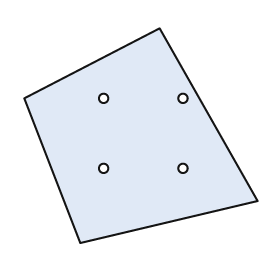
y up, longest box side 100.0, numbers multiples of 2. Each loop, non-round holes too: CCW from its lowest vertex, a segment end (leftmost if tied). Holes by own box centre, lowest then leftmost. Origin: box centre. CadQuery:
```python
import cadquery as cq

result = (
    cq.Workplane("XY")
    .moveTo(-26.0, -46.0)
    .lineTo(50.0, -28.0)
    .lineTo(8.0, 46.0)
    .lineTo(-50.0, 16.0)
    .close()
    .moveTo(-16.0, -14.0)
    .circle(2.0)
    .moveTo(18.0, -14.0)
    .circle(2.0)
    .moveTo(-16.0, 16.0)
    .circle(2.0)
    .moveTo(18.0, 16.0)
    .circle(2.0)
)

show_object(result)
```